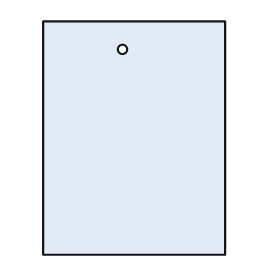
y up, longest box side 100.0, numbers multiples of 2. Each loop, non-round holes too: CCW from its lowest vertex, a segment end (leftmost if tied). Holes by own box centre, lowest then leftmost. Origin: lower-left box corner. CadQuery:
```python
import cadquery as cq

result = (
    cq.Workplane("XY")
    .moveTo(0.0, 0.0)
    .lineTo(78.0, 0.0)
    .lineTo(78.0, 100.0)
    .lineTo(0.0, 100.0)
    .close()
    .moveTo(34.0, 88.0)
    .circle(2.0)
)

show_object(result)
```